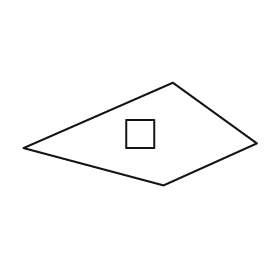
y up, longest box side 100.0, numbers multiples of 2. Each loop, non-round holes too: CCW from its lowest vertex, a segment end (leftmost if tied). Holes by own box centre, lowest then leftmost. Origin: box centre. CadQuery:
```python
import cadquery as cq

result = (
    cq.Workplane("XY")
    .moveTo(10.0, -22.0)
    .lineTo(50.0, -4.0)
    .lineTo(14.0, 22.0)
    .lineTo(-50.0, -6.0)
    .close()
    .moveTo(-6.0, -6.0)
    .lineTo(6.0, -6.0)
    .lineTo(6.0, 6.0)
    .lineTo(-6.0, 6.0)
    .close()
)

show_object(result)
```